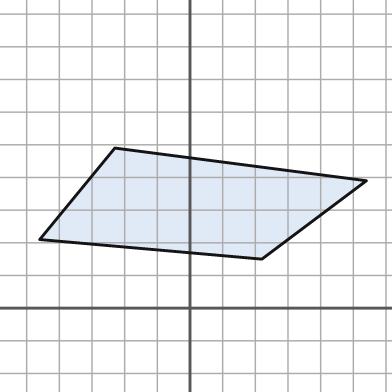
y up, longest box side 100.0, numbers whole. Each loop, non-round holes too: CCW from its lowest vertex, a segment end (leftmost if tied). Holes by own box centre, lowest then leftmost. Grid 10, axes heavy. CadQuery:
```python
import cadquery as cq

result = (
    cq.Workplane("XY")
    .moveTo(22.0, 15.0)
    .lineTo(54.0, 39.0)
    .lineTo(-23.0, 49.0)
    .lineTo(-46.0, 21.0)
    .close()
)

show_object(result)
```